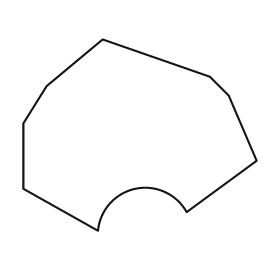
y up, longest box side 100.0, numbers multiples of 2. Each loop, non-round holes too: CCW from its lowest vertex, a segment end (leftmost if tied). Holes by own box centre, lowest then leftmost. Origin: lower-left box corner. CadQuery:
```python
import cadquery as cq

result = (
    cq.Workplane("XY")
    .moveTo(32.0, 0.0)
    .threePointArc((48.0, 18.0), (70.0, 8.0))
    .lineTo(100.0, 30.0)
    .lineTo(88.0, 58.0)
    .lineTo(80.0, 66.0)
    .lineTo(34.0, 82.0)
    .lineTo(10.0, 62.0)
    .lineTo(0.0, 46.0)
    .lineTo(0.0, 18.0)
    .close()
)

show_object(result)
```